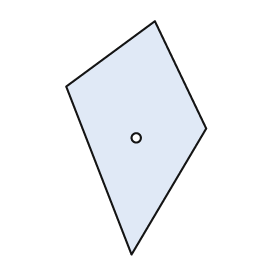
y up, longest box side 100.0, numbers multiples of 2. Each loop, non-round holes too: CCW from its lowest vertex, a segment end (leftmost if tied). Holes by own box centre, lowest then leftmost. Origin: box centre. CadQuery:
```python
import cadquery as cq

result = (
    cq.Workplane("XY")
    .moveTo(-2.0, -50.0)
    .lineTo(30.0, 4.0)
    .lineTo(8.0, 50.0)
    .lineTo(-30.0, 22.0)
    .close()
    .moveTo(0.0, 0.0)
    .circle(2.0)
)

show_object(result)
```